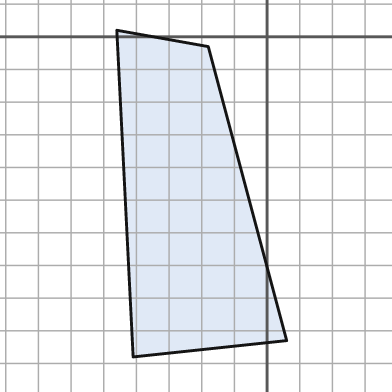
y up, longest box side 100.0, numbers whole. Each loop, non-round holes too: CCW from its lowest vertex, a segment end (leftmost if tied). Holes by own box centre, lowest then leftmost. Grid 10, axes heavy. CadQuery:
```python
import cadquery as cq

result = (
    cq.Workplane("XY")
    .moveTo(-41.0, -98.0)
    .lineTo(6.0, -93.0)
    .lineTo(-18.0, -3.0)
    .lineTo(-46.0, 2.0)
    .close()
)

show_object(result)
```